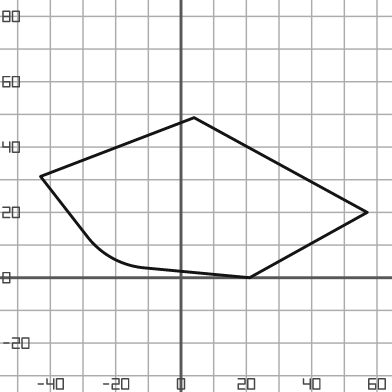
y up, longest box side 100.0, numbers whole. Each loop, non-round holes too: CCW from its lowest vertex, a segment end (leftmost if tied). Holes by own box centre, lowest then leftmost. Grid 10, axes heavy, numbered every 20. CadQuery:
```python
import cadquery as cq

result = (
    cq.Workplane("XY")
    .moveTo(21.0, 0.0)
    .lineTo(57.0, 20.0)
    .lineTo(4.0, 49.0)
    .lineTo(-43.0, 31.0)
    .lineTo(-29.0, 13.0)
    .threePointArc((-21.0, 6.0), (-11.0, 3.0))
    .close()
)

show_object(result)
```